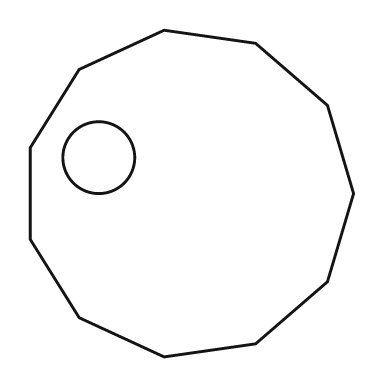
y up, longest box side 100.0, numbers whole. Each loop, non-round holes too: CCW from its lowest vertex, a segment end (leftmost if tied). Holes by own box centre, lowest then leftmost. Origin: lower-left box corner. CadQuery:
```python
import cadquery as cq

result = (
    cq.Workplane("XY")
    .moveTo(41.0, 0.0)
    .lineTo(69.0, 4.0)
    .lineTo(91.0, 23.0)
    .lineTo(99.0, 50.0)
    .lineTo(91.0, 77.0)
    .lineTo(69.0, 96.0)
    .lineTo(41.0, 100.0)
    .lineTo(15.0, 88.0)
    .lineTo(0.0, 64.0)
    .lineTo(0.0, 36.0)
    .lineTo(15.0, 12.0)
    .close()
    .moveTo(21.0, 61.0)
    .circle(11.0)
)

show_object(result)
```